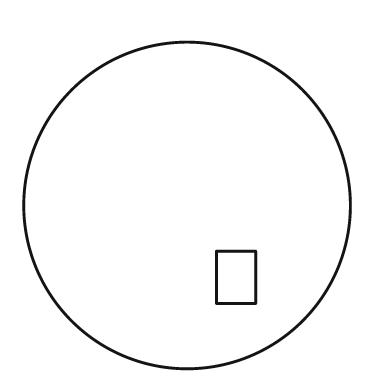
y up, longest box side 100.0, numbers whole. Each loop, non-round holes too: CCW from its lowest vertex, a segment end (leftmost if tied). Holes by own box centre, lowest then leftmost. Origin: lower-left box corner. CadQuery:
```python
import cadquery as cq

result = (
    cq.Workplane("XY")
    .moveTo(50.0, 50.0)
    .circle(50.0)
    .moveTo(59.0, 20.0)
    .lineTo(71.0, 20.0)
    .lineTo(71.0, 36.0)
    .lineTo(59.0, 36.0)
    .close()
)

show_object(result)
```